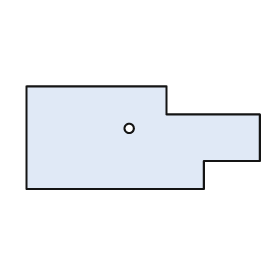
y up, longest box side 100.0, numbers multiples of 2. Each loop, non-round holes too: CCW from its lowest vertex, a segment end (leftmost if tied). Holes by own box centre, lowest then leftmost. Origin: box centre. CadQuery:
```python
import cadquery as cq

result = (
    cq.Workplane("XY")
    .moveTo(-50.0, -22.0)
    .lineTo(26.0, -22.0)
    .lineTo(26.0, -10.0)
    .lineTo(50.0, -10.0)
    .lineTo(50.0, 10.0)
    .lineTo(10.0, 10.0)
    .lineTo(10.0, 22.0)
    .lineTo(-50.0, 22.0)
    .close()
    .moveTo(-6.0, 4.0)
    .circle(2.0)
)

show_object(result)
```